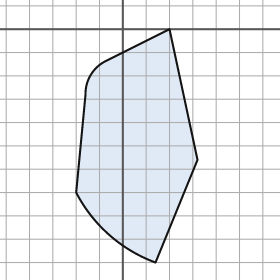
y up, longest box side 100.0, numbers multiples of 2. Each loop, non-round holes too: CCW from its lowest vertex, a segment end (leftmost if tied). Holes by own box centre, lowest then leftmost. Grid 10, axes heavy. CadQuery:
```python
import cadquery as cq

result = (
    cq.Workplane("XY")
    .moveTo(14.0, -100.0)
    .lineTo(32.0, -56.0)
    .lineTo(20.0, 0.0)
    .lineTo(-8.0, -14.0)
    .threePointArc((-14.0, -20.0), (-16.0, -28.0))
    .lineTo(-20.0, -70.0)
    .threePointArc((-6.0, -88.0), (14.0, -100.0))
    .close()
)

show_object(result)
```